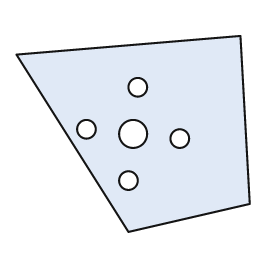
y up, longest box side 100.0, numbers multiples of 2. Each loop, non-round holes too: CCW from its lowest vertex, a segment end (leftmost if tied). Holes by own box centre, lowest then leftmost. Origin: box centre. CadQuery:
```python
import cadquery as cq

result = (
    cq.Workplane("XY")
    .moveTo(-2.0, -42.0)
    .lineTo(50.0, -30.0)
    .lineTo(46.0, 42.0)
    .lineTo(-50.0, 34.0)
    .close()
    .moveTo(-2.0, -20.0)
    .circle(4.0)
    .moveTo(20.0, -2.0)
    .circle(4.0)
    .moveTo(0.0, 0.0)
    .circle(6.0)
    .moveTo(-20.0, 2.0)
    .circle(4.0)
    .moveTo(2.0, 20.0)
    .circle(4.0)
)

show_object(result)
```